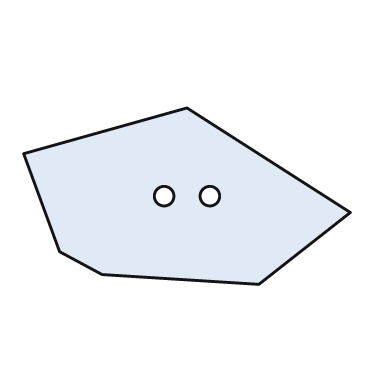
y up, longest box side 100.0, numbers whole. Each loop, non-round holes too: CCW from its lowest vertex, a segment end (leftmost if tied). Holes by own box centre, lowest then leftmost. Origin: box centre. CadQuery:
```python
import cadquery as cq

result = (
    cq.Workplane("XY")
    .moveTo(22.0, -27.0)
    .lineTo(50.0, -5.0)
    .lineTo(0.0, 27.0)
    .lineTo(-50.0, 13.0)
    .lineTo(-39.0, -17.0)
    .lineTo(-26.0, -24.0)
    .close()
    .moveTo(-7.0, 0.0)
    .circle(3.0)
    .moveTo(7.0, 0.0)
    .circle(3.0)
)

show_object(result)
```